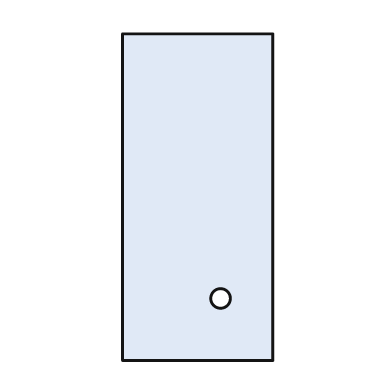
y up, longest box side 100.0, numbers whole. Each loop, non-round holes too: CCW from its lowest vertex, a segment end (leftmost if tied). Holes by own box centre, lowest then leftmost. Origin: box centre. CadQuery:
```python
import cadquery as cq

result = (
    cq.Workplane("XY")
    .moveTo(-23.0, -50.0)
    .lineTo(23.0, -50.0)
    .lineTo(23.0, 50.0)
    .lineTo(-23.0, 50.0)
    .close()
    .moveTo(7.0, -31.0)
    .circle(3.0)
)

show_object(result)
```